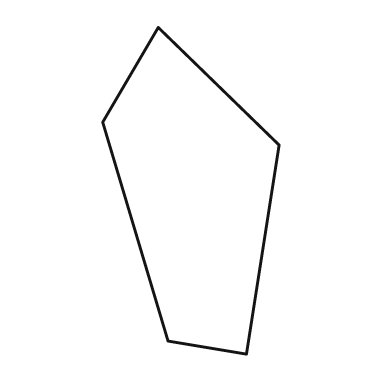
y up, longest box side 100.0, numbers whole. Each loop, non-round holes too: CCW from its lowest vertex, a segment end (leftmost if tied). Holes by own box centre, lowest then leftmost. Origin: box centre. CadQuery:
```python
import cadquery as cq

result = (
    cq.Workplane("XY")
    .moveTo(17.0, -50.0)
    .lineTo(27.0, 14.0)
    .lineTo(-10.0, 50.0)
    .lineTo(-27.0, 21.0)
    .lineTo(-7.0, -46.0)
    .close()
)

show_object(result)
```